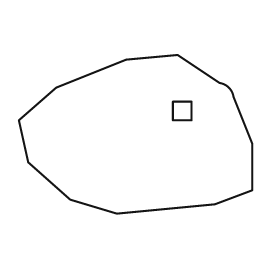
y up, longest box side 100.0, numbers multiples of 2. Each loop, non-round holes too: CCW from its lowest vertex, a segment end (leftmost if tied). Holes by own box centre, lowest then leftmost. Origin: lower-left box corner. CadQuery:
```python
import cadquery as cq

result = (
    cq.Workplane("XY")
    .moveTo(42.0, 0.0)
    .lineTo(84.0, 4.0)
    .lineTo(100.0, 10.0)
    .lineTo(100.0, 30.0)
    .lineTo(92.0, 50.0)
    .threePointArc((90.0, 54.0), (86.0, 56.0))
    .lineTo(68.0, 68.0)
    .lineTo(46.0, 66.0)
    .lineTo(16.0, 54.0)
    .lineTo(0.0, 40.0)
    .lineTo(4.0, 22.0)
    .lineTo(22.0, 6.0)
    .close()
    .moveTo(66.0, 40.0)
    .lineTo(74.0, 40.0)
    .lineTo(74.0, 48.0)
    .lineTo(66.0, 48.0)
    .close()
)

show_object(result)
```